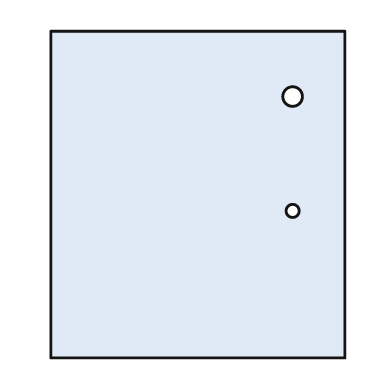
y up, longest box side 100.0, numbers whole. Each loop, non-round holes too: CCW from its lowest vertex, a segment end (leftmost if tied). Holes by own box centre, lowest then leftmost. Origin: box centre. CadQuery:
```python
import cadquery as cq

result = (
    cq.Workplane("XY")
    .moveTo(-45.0, -50.0)
    .lineTo(45.0, -50.0)
    .lineTo(45.0, 50.0)
    .lineTo(-45.0, 50.0)
    .close()
    .moveTo(29.0, -5.0)
    .circle(2.0)
    .moveTo(29.0, 30.0)
    .circle(3.0)
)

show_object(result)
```